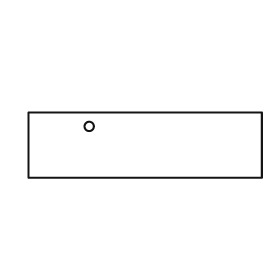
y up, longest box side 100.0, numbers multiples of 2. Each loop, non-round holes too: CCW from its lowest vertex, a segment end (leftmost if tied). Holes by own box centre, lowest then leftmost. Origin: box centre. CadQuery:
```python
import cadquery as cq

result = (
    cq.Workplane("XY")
    .moveTo(-50.0, -14.0)
    .lineTo(50.0, -14.0)
    .lineTo(50.0, 14.0)
    .lineTo(-50.0, 14.0)
    .close()
    .moveTo(-24.0, 8.0)
    .circle(2.0)
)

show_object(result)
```